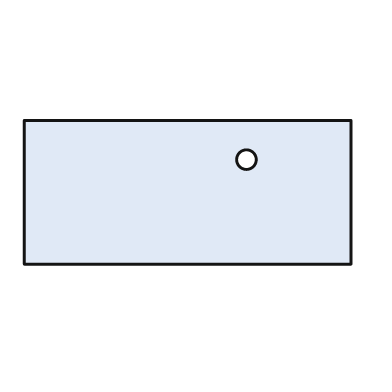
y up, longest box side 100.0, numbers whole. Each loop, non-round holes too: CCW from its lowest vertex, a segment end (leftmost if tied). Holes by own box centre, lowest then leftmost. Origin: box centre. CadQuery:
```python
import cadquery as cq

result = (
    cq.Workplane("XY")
    .moveTo(-50.0, -22.0)
    .lineTo(50.0, -22.0)
    .lineTo(50.0, 22.0)
    .lineTo(-50.0, 22.0)
    .close()
    .moveTo(18.0, 10.0)
    .circle(3.0)
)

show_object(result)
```